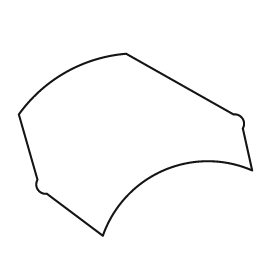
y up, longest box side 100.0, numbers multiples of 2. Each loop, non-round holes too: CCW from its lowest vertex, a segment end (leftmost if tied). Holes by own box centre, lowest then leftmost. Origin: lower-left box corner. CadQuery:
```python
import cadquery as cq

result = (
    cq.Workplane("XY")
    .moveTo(36.0, 0.0)
    .threePointArc((62.0, 28.0), (100.0, 28.0))
    .lineTo(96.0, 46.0)
    .threePointArc((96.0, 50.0), (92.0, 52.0))
    .lineTo(46.0, 78.0)
    .threePointArc((20.0, 70.0), (0.0, 52.0))
    .lineTo(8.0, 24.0)
    .threePointArc((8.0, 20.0), (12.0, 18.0))
    .close()
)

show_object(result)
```